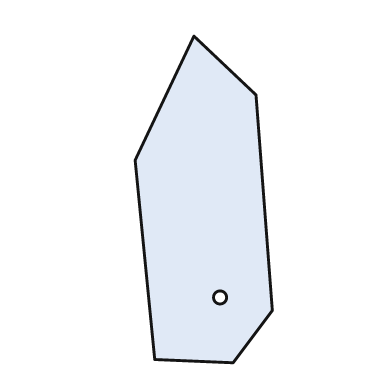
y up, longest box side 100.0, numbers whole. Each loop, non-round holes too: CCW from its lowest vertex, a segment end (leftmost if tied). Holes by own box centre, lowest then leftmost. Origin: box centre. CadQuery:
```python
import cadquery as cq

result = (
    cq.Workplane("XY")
    .moveTo(9.0, -50.0)
    .lineTo(21.0, -34.0)
    .lineTo(16.0, 32.0)
    .lineTo(-3.0, 50.0)
    .lineTo(-21.0, 12.0)
    .lineTo(-15.0, -49.0)
    .close()
    .moveTo(5.0, -30.0)
    .circle(2.0)
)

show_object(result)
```